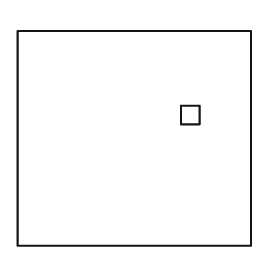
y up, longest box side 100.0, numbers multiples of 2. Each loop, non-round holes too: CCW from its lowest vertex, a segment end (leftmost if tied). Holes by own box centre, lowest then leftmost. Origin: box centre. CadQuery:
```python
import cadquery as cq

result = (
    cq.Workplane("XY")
    .moveTo(-50.0, -46.0)
    .lineTo(50.0, -46.0)
    .lineTo(50.0, 46.0)
    .lineTo(-50.0, 46.0)
    .close()
    .moveTo(20.0, 6.0)
    .lineTo(28.0, 6.0)
    .lineTo(28.0, 14.0)
    .lineTo(20.0, 14.0)
    .close()
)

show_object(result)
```